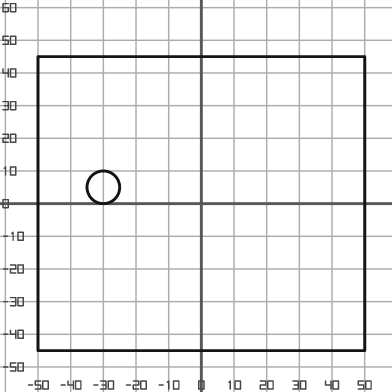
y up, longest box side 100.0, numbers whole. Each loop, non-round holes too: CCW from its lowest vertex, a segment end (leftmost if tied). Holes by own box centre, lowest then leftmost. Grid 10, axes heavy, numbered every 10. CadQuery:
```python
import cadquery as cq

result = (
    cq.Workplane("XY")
    .moveTo(-50.0, -45.0)
    .lineTo(50.0, -45.0)
    .lineTo(50.0, 45.0)
    .lineTo(-50.0, 45.0)
    .close()
    .moveTo(-30.0, 5.0)
    .circle(5.0)
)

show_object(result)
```